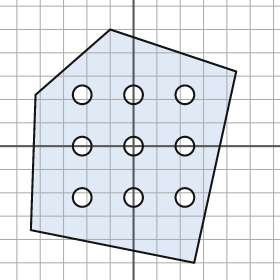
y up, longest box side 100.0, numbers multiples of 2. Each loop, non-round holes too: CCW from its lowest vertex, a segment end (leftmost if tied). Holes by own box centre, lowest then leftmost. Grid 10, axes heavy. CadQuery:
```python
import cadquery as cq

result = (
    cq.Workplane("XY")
    .moveTo(26.0, -50.0)
    .lineTo(44.0, 32.0)
    .lineTo(-10.0, 50.0)
    .lineTo(-42.0, 22.0)
    .lineTo(-44.0, -36.0)
    .close()
    .moveTo(-22.0, -22.0)
    .circle(4.0)
    .moveTo(0.0, -22.0)
    .circle(4.0)
    .moveTo(22.0, -22.0)
    .circle(4.0)
    .moveTo(-22.0, 0.0)
    .circle(4.0)
    .moveTo(0.0, 0.0)
    .circle(4.0)
    .moveTo(22.0, 0.0)
    .circle(4.0)
    .moveTo(-22.0, 22.0)
    .circle(4.0)
    .moveTo(0.0, 22.0)
    .circle(4.0)
    .moveTo(22.0, 22.0)
    .circle(4.0)
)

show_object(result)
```